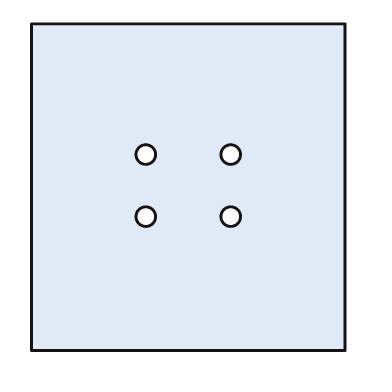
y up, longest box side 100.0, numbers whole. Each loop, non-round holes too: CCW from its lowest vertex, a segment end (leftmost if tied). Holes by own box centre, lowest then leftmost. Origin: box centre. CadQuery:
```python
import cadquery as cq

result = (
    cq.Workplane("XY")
    .moveTo(-48.0, -50.0)
    .lineTo(48.0, -50.0)
    .lineTo(48.0, 50.0)
    .lineTo(-48.0, 50.0)
    .close()
    .moveTo(-13.0, -9.0)
    .circle(3.0)
    .moveTo(13.0, -9.0)
    .circle(3.0)
    .moveTo(-13.0, 10.0)
    .circle(3.0)
    .moveTo(13.0, 10.0)
    .circle(3.0)
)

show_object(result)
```